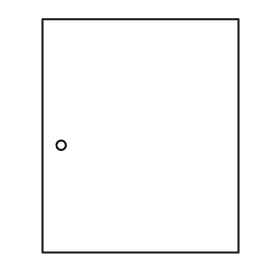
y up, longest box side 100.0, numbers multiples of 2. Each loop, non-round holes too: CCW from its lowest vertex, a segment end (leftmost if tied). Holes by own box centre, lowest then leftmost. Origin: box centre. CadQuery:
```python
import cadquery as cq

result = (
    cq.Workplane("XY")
    .moveTo(-42.0, -50.0)
    .lineTo(42.0, -50.0)
    .lineTo(42.0, 50.0)
    .lineTo(-42.0, 50.0)
    .close()
    .moveTo(-34.0, -4.0)
    .circle(2.0)
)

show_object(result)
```